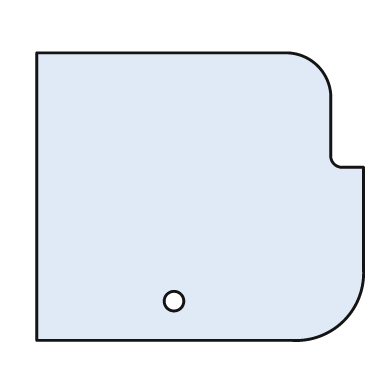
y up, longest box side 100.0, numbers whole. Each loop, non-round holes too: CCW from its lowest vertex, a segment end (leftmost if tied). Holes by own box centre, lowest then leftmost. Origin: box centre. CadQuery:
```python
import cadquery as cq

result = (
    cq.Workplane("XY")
    .moveTo(-50.0, -44.0)
    .lineTo(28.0, -44.0)
    .threePointArc((44.0, -38.0), (50.0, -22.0))
    .lineTo(50.0, 9.0)
    .lineTo(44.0, 9.0)
    .threePointArc((41.0, 10.0), (40.0, 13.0))
    .lineTo(40.0, 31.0)
    .threePointArc((36.0, 40.0), (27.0, 44.0))
    .lineTo(-50.0, 44.0)
    .close()
    .moveTo(-8.0, -32.0)
    .circle(3.0)
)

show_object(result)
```